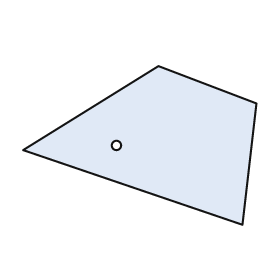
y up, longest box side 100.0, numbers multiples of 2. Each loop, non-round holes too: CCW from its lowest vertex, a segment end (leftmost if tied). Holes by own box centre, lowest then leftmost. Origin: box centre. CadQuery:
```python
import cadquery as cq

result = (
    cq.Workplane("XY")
    .moveTo(44.0, -34.0)
    .lineTo(50.0, 18.0)
    .lineTo(8.0, 34.0)
    .lineTo(-50.0, -2.0)
    .close()
    .moveTo(-10.0, 0.0)
    .circle(2.0)
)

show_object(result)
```